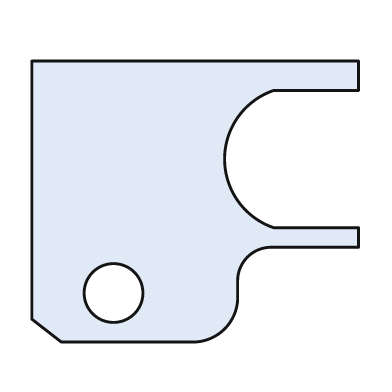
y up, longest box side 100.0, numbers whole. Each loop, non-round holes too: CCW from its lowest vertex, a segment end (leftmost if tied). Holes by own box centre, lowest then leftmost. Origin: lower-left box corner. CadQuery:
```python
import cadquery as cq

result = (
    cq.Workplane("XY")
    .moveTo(9.0, 0.0)
    .lineTo(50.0, 0.0)
    .threePointArc((59.0, 4.0), (63.0, 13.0))
    .lineTo(63.0, 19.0)
    .threePointArc((66.0, 26.0), (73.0, 29.0))
    .lineTo(100.0, 29.0)
    .lineTo(100.0, 35.0)
    .lineTo(74.0, 35.0)
    .threePointArc((59.0, 56.0), (74.0, 77.0))
    .lineTo(100.0, 77.0)
    .lineTo(100.0, 86.0)
    .lineTo(0.0, 86.0)
    .lineTo(0.0, 7.0)
    .close()
    .moveTo(25.0, 15.0)
    .circle(9.0)
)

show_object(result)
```